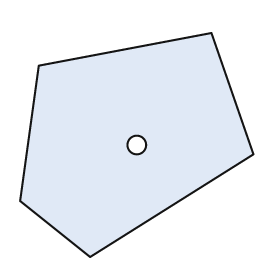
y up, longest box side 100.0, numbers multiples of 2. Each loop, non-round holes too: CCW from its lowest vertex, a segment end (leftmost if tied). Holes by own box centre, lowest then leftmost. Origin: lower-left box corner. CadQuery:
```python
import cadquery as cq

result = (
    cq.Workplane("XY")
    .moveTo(30.0, 0.0)
    .lineTo(100.0, 44.0)
    .lineTo(82.0, 96.0)
    .lineTo(8.0, 82.0)
    .lineTo(0.0, 24.0)
    .close()
    .moveTo(50.0, 48.0)
    .circle(4.0)
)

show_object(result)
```